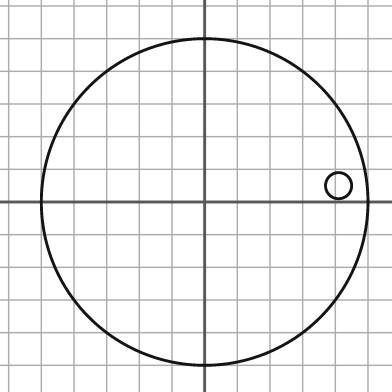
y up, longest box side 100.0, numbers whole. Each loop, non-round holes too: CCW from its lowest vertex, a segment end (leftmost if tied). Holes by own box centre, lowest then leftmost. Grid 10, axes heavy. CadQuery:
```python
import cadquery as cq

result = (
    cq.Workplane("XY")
    .moveTo(0.0, 0.0)
    .circle(50.0)
    .moveTo(41.0, 5.0)
    .circle(4.0)
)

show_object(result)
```